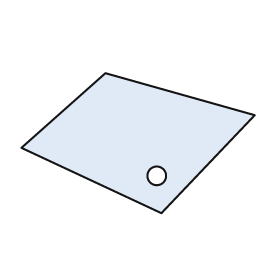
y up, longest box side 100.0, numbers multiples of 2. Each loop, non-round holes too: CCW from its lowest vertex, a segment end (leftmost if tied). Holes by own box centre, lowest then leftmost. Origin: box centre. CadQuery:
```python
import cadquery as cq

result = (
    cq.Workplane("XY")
    .moveTo(10.0, -30.0)
    .lineTo(50.0, 12.0)
    .lineTo(-14.0, 30.0)
    .lineTo(-50.0, -2.0)
    .close()
    .moveTo(8.0, -14.0)
    .circle(4.0)
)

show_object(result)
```